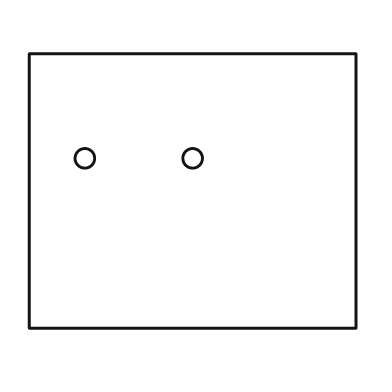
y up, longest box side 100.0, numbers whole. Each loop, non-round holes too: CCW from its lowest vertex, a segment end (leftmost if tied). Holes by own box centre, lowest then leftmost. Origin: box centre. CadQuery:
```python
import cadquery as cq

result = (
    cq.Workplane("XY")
    .moveTo(-50.0, -42.0)
    .lineTo(50.0, -42.0)
    .lineTo(50.0, 42.0)
    .lineTo(-50.0, 42.0)
    .close()
    .moveTo(-33.0, 10.0)
    .circle(3.0)
    .moveTo(0.0, 10.0)
    .circle(3.0)
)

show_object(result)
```